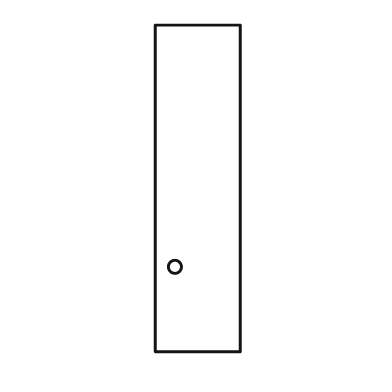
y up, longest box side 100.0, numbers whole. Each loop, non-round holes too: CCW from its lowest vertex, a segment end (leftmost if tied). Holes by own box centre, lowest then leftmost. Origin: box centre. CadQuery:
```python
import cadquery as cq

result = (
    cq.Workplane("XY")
    .moveTo(-13.0, -50.0)
    .lineTo(13.0, -50.0)
    .lineTo(13.0, 50.0)
    .lineTo(-13.0, 50.0)
    .close()
    .moveTo(-7.0, -24.0)
    .circle(2.0)
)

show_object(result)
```